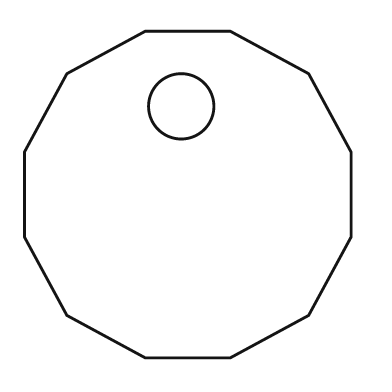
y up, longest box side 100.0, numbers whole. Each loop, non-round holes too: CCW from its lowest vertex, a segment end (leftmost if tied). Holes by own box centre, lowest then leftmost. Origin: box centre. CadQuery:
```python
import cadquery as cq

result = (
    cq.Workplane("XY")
    .moveTo(-13.0, -50.0)
    .lineTo(13.0, -50.0)
    .lineTo(37.0, -37.0)
    .lineTo(50.0, -13.0)
    .lineTo(50.0, 13.0)
    .lineTo(37.0, 37.0)
    .lineTo(13.0, 50.0)
    .lineTo(-13.0, 50.0)
    .lineTo(-37.0, 37.0)
    .lineTo(-50.0, 13.0)
    .lineTo(-50.0, -13.0)
    .lineTo(-37.0, -37.0)
    .close()
    .moveTo(-2.0, 27.0)
    .circle(10.0)
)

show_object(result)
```